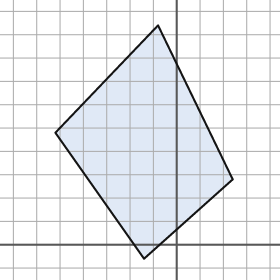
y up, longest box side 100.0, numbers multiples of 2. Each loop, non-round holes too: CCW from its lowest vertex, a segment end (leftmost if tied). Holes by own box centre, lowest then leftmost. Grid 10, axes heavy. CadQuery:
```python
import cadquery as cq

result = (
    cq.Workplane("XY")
    .moveTo(-14.0, -6.0)
    .lineTo(24.0, 28.0)
    .lineTo(-8.0, 94.0)
    .lineTo(-52.0, 48.0)
    .close()
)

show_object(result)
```